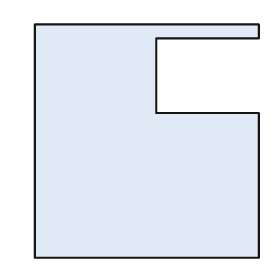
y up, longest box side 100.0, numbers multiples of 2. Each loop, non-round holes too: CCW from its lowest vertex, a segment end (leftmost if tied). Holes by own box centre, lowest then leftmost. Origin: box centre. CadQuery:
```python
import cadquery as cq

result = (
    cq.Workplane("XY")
    .moveTo(-48.0, -50.0)
    .lineTo(48.0, -50.0)
    .lineTo(48.0, 12.0)
    .lineTo(4.0, 12.0)
    .lineTo(4.0, 44.0)
    .lineTo(48.0, 44.0)
    .lineTo(48.0, 50.0)
    .lineTo(-48.0, 50.0)
    .close()
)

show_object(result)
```